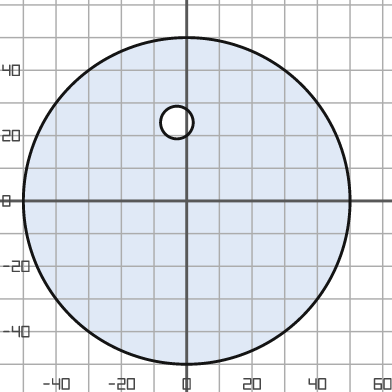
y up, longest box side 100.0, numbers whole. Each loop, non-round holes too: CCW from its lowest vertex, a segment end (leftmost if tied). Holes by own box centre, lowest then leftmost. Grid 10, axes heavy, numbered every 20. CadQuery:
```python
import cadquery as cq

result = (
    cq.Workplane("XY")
    .moveTo(0.0, 0.0)
    .circle(50.0)
    .moveTo(-3.0, 24.0)
    .circle(5.0)
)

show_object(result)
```